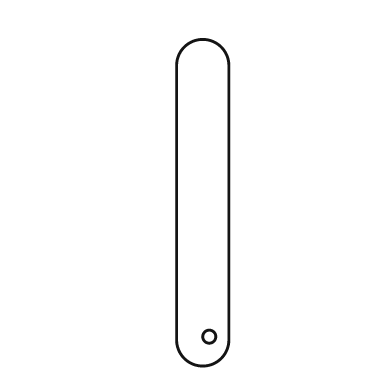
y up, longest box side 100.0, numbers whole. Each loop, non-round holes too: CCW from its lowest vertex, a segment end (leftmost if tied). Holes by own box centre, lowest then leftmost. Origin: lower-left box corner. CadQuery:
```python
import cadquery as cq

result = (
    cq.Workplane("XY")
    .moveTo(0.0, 8.0)
    .threePointArc((8.0, 0.0), (16.0, 8.0))
    .lineTo(16.0, 92.0)
    .threePointArc((8.0, 100.0), (0.0, 92.0))
    .close()
    .moveTo(10.0, 9.0)
    .circle(2.0)
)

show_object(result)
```